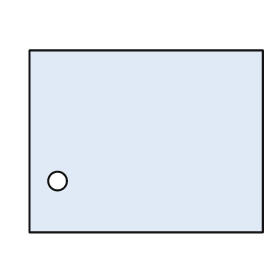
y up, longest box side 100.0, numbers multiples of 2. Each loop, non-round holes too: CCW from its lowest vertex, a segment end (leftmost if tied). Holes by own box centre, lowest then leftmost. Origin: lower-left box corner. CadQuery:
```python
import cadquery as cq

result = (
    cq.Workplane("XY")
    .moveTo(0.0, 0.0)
    .lineTo(100.0, 0.0)
    .lineTo(100.0, 78.0)
    .lineTo(0.0, 78.0)
    .close()
    .moveTo(12.0, 22.0)
    .circle(4.0)
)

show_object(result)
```